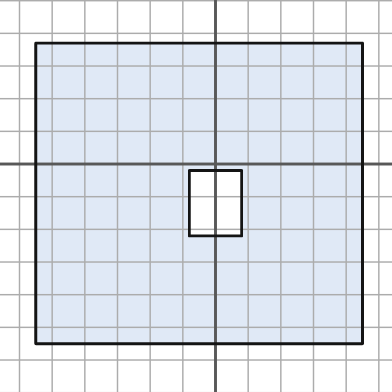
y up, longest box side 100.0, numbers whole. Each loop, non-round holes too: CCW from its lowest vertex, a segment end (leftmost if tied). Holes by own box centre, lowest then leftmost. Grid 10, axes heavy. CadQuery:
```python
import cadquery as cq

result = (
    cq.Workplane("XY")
    .moveTo(-55.0, -55.0)
    .lineTo(45.0, -55.0)
    .lineTo(45.0, 37.0)
    .lineTo(-55.0, 37.0)
    .close()
    .moveTo(-8.0, -22.0)
    .lineTo(8.0, -22.0)
    .lineTo(8.0, -2.0)
    .lineTo(-8.0, -2.0)
    .close()
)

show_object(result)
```